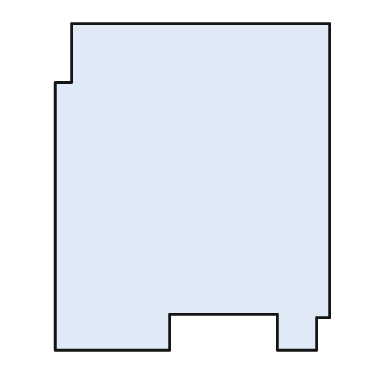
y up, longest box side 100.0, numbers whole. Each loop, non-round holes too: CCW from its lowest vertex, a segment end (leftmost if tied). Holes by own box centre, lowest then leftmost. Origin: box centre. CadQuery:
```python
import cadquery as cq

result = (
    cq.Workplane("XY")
    .moveTo(-42.0, -50.0)
    .lineTo(-7.0, -50.0)
    .lineTo(-7.0, -39.0)
    .lineTo(26.0, -39.0)
    .lineTo(26.0, -50.0)
    .lineTo(38.0, -50.0)
    .lineTo(38.0, -40.0)
    .lineTo(42.0, -40.0)
    .lineTo(42.0, 50.0)
    .lineTo(-37.0, 50.0)
    .lineTo(-37.0, 32.0)
    .lineTo(-42.0, 32.0)
    .close()
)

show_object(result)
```